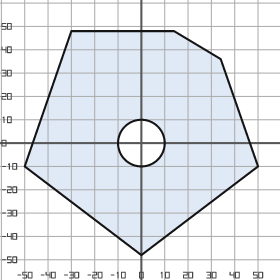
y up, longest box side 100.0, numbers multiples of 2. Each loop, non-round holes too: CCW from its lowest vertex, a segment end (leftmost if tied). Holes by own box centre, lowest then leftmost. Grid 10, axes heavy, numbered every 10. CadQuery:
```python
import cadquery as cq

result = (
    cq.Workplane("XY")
    .moveTo(0.0, -48.0)
    .lineTo(50.0, -10.0)
    .lineTo(34.0, 36.0)
    .lineTo(14.0, 48.0)
    .lineTo(-30.0, 48.0)
    .lineTo(-50.0, -10.0)
    .close()
    .moveTo(0.0, 0.0)
    .circle(10.0)
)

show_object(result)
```